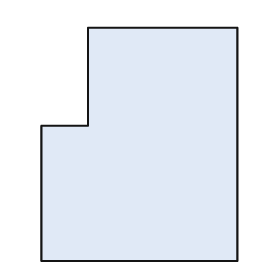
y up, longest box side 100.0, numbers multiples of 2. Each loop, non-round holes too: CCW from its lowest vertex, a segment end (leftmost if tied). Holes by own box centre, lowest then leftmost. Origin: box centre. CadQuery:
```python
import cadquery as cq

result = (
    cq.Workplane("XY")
    .moveTo(-42.0, -50.0)
    .lineTo(42.0, -50.0)
    .lineTo(42.0, 50.0)
    .lineTo(-22.0, 50.0)
    .lineTo(-22.0, 8.0)
    .lineTo(-42.0, 8.0)
    .close()
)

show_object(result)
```